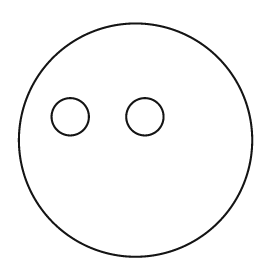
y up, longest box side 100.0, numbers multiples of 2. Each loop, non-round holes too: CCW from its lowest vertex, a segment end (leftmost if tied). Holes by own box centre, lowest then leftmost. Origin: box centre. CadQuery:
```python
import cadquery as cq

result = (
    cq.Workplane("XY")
    .moveTo(0.0, 0.0)
    .circle(50.0)
    .moveTo(-28.0, 10.0)
    .circle(8.0)
    .moveTo(4.0, 10.0)
    .circle(8.0)
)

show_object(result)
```